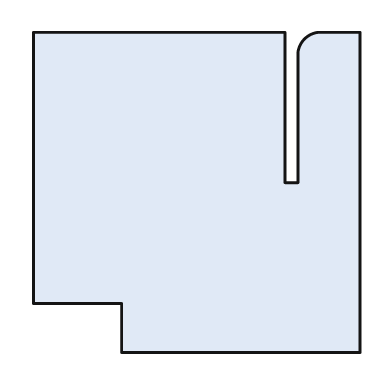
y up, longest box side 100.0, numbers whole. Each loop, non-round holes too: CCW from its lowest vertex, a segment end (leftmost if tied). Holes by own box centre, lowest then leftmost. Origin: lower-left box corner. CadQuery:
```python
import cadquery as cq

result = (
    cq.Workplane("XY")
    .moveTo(27.0, 0.0)
    .lineTo(100.0, 0.0)
    .lineTo(100.0, 98.0)
    .lineTo(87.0, 98.0)
    .threePointArc((83.0, 96.0), (81.0, 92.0))
    .lineTo(81.0, 52.0)
    .lineTo(77.0, 52.0)
    .lineTo(77.0, 98.0)
    .lineTo(0.0, 98.0)
    .lineTo(0.0, 15.0)
    .lineTo(27.0, 15.0)
    .close()
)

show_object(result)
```